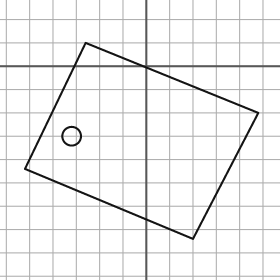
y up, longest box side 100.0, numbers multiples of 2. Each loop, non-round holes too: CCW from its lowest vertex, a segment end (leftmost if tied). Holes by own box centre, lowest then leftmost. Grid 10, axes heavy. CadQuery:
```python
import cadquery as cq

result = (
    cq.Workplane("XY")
    .moveTo(20.0, -74.0)
    .lineTo(48.0, -20.0)
    .lineTo(-26.0, 10.0)
    .lineTo(-52.0, -44.0)
    .close()
    .moveTo(-32.0, -30.0)
    .circle(4.0)
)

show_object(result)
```